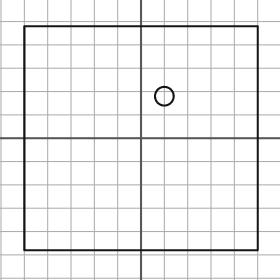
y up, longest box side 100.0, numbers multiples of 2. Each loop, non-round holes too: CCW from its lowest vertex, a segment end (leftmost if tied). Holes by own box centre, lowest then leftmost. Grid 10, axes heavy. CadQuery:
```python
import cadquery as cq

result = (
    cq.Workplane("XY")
    .moveTo(-50.0, -48.0)
    .lineTo(50.0, -48.0)
    .lineTo(50.0, 48.0)
    .lineTo(-50.0, 48.0)
    .close()
    .moveTo(10.0, 18.0)
    .circle(4.0)
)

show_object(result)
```